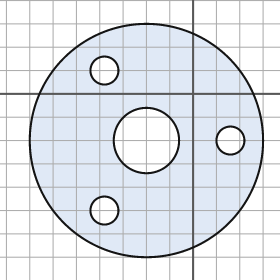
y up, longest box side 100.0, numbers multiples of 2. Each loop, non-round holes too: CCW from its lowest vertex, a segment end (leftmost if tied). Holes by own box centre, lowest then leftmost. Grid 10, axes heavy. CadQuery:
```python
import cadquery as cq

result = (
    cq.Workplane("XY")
    .moveTo(-20.0, -20.0)
    .circle(50.0)
    .moveTo(-38.0, -50.0)
    .circle(6.0)
    .moveTo(-20.0, -20.0)
    .circle(14.0)
    .moveTo(16.0, -20.0)
    .circle(6.0)
    .moveTo(-38.0, 10.0)
    .circle(6.0)
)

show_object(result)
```